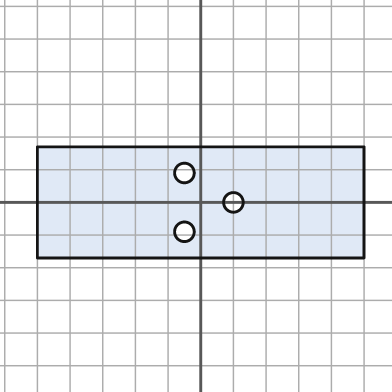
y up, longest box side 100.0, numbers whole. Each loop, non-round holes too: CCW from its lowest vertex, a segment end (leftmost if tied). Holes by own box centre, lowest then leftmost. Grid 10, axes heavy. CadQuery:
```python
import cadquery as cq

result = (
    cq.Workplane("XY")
    .moveTo(-50.0, -17.0)
    .lineTo(50.0, -17.0)
    .lineTo(50.0, 17.0)
    .lineTo(-50.0, 17.0)
    .close()
    .moveTo(-5.0, -9.0)
    .circle(3.0)
    .moveTo(10.0, 0.0)
    .circle(3.0)
    .moveTo(-5.0, 9.0)
    .circle(3.0)
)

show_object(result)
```